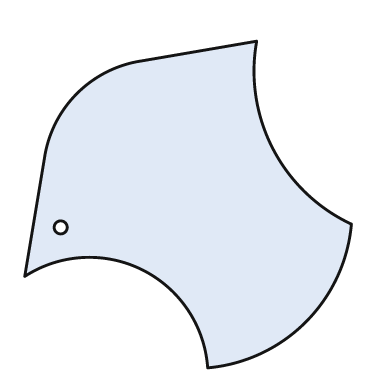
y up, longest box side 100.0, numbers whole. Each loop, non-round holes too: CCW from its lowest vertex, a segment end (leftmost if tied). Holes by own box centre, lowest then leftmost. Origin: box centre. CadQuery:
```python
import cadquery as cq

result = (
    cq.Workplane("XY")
    .moveTo(6.0, -50.0)
    .threePointArc((36.0, -36.0), (50.0, -6.0))
    .threePointArc((26.0, 17.0), (21.0, 50.0))
    .lineTo(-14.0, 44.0)
    .threePointArc((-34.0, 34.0), (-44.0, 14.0))
    .lineTo(-50.0, -22.0)
    .threePointArc((-14.0, -20.0), (6.0, -50.0))
    .close()
    .moveTo(-39.0, -7.0)
    .circle(2.0)
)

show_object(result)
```